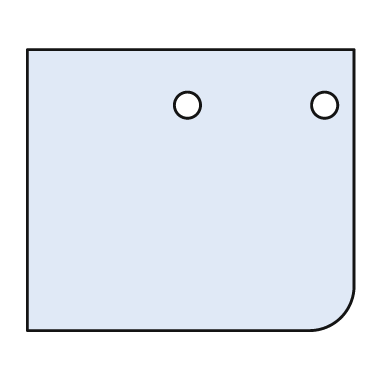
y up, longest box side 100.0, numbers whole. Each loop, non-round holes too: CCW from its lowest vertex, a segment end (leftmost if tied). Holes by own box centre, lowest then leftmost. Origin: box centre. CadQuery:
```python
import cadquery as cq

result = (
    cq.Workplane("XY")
    .moveTo(-50.0, -43.0)
    .lineTo(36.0, -43.0)
    .threePointArc((46.0, -39.0), (50.0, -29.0))
    .lineTo(50.0, 43.0)
    .lineTo(-50.0, 43.0)
    .close()
    .moveTo(-1.0, 26.0)
    .circle(4.0)
    .moveTo(41.0, 26.0)
    .circle(4.0)
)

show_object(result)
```